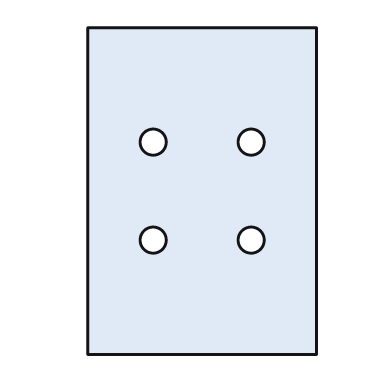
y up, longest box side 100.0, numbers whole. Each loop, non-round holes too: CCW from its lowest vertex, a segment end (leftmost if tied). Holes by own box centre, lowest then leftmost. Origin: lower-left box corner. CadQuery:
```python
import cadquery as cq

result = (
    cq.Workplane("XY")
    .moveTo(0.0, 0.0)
    .lineTo(70.0, 0.0)
    .lineTo(70.0, 100.0)
    .lineTo(0.0, 100.0)
    .close()
    .moveTo(20.0, 35.0)
    .circle(4.0)
    .moveTo(50.0, 35.0)
    .circle(4.0)
    .moveTo(20.0, 65.0)
    .circle(4.0)
    .moveTo(50.0, 65.0)
    .circle(4.0)
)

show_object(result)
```